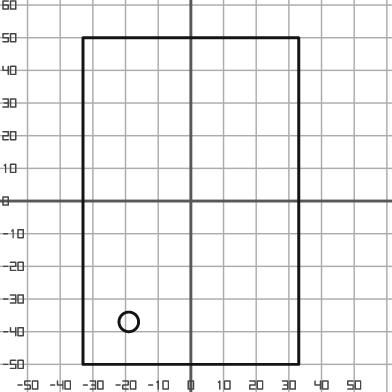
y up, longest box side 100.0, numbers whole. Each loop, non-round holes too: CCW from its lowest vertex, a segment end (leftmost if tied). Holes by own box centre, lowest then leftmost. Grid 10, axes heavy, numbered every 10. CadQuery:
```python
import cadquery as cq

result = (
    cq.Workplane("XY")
    .moveTo(-33.0, -50.0)
    .lineTo(33.0, -50.0)
    .lineTo(33.0, 50.0)
    .lineTo(-33.0, 50.0)
    .close()
    .moveTo(-19.0, -37.0)
    .circle(3.0)
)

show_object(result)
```